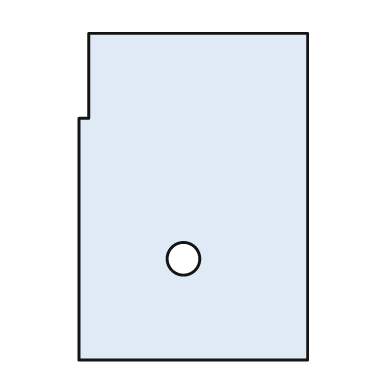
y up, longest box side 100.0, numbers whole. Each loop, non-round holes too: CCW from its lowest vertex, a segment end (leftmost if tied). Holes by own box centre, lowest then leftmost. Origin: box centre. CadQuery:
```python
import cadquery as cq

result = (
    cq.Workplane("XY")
    .moveTo(-35.0, -50.0)
    .lineTo(35.0, -50.0)
    .lineTo(35.0, 50.0)
    .lineTo(-32.0, 50.0)
    .lineTo(-32.0, 24.0)
    .lineTo(-35.0, 24.0)
    .close()
    .moveTo(-3.0, -19.0)
    .circle(5.0)
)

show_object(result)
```